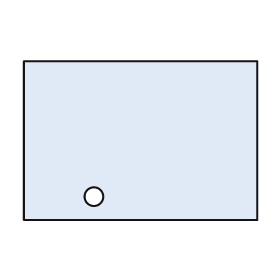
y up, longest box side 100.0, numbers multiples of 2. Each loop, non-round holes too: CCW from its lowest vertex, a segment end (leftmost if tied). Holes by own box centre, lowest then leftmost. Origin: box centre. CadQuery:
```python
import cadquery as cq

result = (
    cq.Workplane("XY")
    .moveTo(-50.0, -34.0)
    .lineTo(50.0, -34.0)
    .lineTo(50.0, 34.0)
    .lineTo(-50.0, 34.0)
    .close()
    .moveTo(-20.0, -24.0)
    .circle(4.0)
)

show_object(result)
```